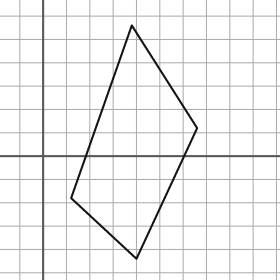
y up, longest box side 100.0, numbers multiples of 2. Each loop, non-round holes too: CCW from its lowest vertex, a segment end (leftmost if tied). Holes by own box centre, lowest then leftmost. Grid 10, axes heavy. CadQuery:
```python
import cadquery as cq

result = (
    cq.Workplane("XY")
    .moveTo(40.0, -44.0)
    .lineTo(66.0, 12.0)
    .lineTo(38.0, 56.0)
    .lineTo(12.0, -18.0)
    .close()
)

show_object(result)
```